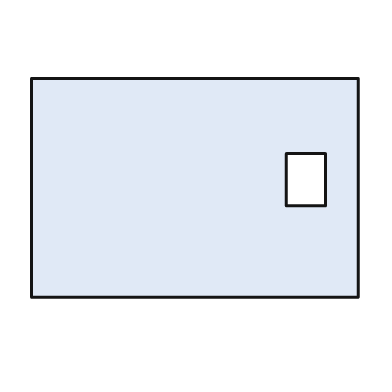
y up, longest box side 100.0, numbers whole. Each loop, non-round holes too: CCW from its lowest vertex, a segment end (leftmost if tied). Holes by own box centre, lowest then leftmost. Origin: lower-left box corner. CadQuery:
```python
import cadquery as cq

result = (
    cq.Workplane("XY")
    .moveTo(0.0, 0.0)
    .lineTo(100.0, 0.0)
    .lineTo(100.0, 67.0)
    .lineTo(0.0, 67.0)
    .close()
    .moveTo(78.0, 28.0)
    .lineTo(90.0, 28.0)
    .lineTo(90.0, 44.0)
    .lineTo(78.0, 44.0)
    .close()
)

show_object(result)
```